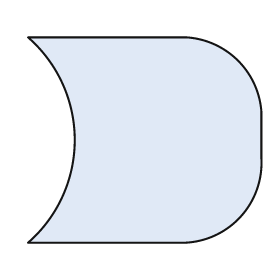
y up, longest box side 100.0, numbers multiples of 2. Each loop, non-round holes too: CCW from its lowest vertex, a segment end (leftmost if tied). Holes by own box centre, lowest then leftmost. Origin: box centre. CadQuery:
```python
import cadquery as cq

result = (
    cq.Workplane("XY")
    .moveTo(-50.0, -44.0)
    .lineTo(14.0, -44.0)
    .threePointArc((40.0, -34.0), (50.0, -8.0))
    .lineTo(50.0, 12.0)
    .threePointArc((40.0, 34.0), (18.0, 44.0))
    .lineTo(-50.0, 44.0)
    .threePointArc((-30.0, 0.0), (-50.0, -44.0))
    .close()
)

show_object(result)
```